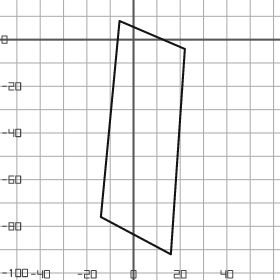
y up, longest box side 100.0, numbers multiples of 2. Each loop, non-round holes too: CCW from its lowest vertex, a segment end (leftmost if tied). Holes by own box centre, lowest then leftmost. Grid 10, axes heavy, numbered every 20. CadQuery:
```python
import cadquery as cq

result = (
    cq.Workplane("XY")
    .moveTo(16.0, -92.0)
    .lineTo(22.0, -4.0)
    .lineTo(-6.0, 8.0)
    .lineTo(-14.0, -76.0)
    .close()
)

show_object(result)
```